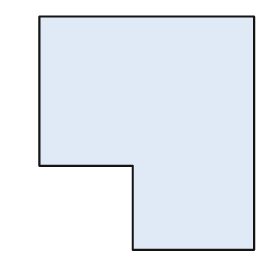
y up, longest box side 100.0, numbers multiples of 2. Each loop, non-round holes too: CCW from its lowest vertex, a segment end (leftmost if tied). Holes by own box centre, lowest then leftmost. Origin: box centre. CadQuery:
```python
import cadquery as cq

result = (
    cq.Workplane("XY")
    .moveTo(-6.0, -50.0)
    .lineTo(46.0, -50.0)
    .lineTo(46.0, 50.0)
    .lineTo(-46.0, 50.0)
    .lineTo(-46.0, -14.0)
    .lineTo(-6.0, -14.0)
    .close()
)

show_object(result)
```